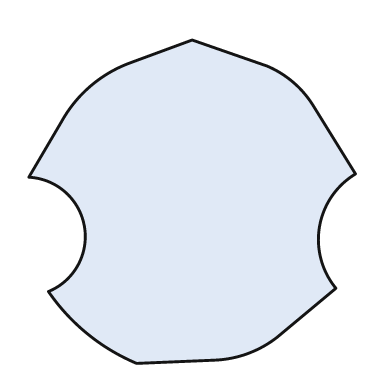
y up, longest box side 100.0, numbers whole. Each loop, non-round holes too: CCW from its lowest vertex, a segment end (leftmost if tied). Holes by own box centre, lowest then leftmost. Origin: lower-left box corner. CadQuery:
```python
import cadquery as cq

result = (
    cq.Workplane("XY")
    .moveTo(33.0, 0.0)
    .lineTo(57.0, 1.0)
    .threePointArc((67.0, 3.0), (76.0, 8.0))
    .lineTo(94.0, 23.0)
    .threePointArc((89.0, 42.0), (100.0, 58.0))
    .lineTo(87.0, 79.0)
    .threePointArc((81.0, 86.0), (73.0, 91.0))
    .lineTo(50.0, 99.0)
    .lineTo(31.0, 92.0)
    .threePointArc((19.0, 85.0), (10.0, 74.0))
    .lineTo(0.0, 57.0)
    .threePointArc((17.0, 42.0), (6.0, 22.0))
    .threePointArc((18.0, 9.0), (33.0, 0.0))
    .close()
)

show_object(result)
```